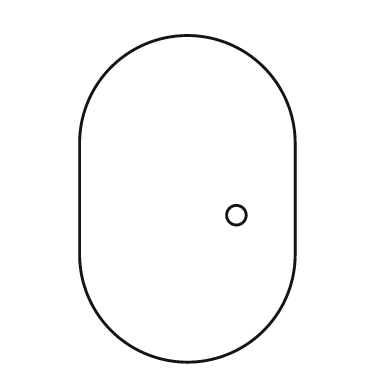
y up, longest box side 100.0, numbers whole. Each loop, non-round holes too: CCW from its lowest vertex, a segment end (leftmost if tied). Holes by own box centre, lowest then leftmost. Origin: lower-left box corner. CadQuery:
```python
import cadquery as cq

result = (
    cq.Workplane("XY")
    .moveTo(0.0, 33.0)
    .threePointArc((33.0, 0.0), (66.0, 33.0))
    .lineTo(66.0, 67.0)
    .threePointArc((33.0, 100.0), (0.0, 67.0))
    .close()
    .moveTo(48.0, 45.0)
    .circle(3.0)
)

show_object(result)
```